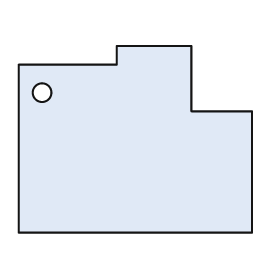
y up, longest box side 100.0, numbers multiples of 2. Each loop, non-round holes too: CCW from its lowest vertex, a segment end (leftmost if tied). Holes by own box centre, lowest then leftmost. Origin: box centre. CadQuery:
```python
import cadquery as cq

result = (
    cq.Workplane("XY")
    .moveTo(-50.0, -40.0)
    .lineTo(50.0, -40.0)
    .lineTo(50.0, 12.0)
    .lineTo(24.0, 12.0)
    .lineTo(24.0, 40.0)
    .lineTo(-8.0, 40.0)
    .lineTo(-8.0, 32.0)
    .lineTo(-50.0, 32.0)
    .close()
    .moveTo(-40.0, 20.0)
    .circle(4.0)
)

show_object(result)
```